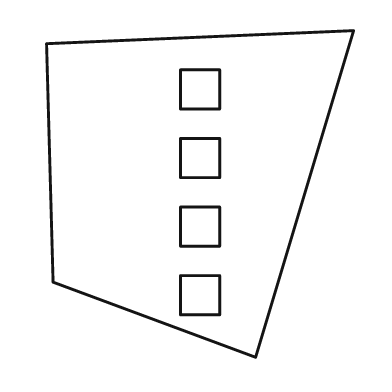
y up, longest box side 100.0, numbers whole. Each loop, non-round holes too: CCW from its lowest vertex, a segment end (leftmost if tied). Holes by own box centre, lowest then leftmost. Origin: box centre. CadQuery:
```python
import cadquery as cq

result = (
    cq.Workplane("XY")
    .moveTo(17.0, -50.0)
    .lineTo(47.0, 50.0)
    .lineTo(-47.0, 46.0)
    .lineTo(-45.0, -27.0)
    .close()
    .moveTo(-6.0, -37.0)
    .lineTo(6.0, -37.0)
    .lineTo(6.0, -25.0)
    .lineTo(-6.0, -25.0)
    .close()
    .moveTo(-6.0, -16.0)
    .lineTo(6.0, -16.0)
    .lineTo(6.0, -4.0)
    .lineTo(-6.0, -4.0)
    .close()
    .moveTo(-6.0, 5.0)
    .lineTo(6.0, 5.0)
    .lineTo(6.0, 17.0)
    .lineTo(-6.0, 17.0)
    .close()
    .moveTo(-6.0, 26.0)
    .lineTo(6.0, 26.0)
    .lineTo(6.0, 38.0)
    .lineTo(-6.0, 38.0)
    .close()
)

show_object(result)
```